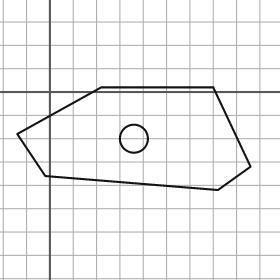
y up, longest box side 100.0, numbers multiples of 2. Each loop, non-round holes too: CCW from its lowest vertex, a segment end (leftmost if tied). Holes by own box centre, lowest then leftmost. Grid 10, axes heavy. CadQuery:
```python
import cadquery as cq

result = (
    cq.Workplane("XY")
    .moveTo(72.0, -42.0)
    .lineTo(86.0, -32.0)
    .lineTo(70.0, 2.0)
    .lineTo(22.0, 2.0)
    .lineTo(-14.0, -18.0)
    .lineTo(-2.0, -36.0)
    .close()
    .moveTo(36.0, -20.0)
    .circle(6.0)
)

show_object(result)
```